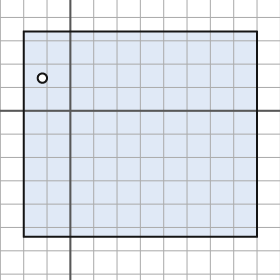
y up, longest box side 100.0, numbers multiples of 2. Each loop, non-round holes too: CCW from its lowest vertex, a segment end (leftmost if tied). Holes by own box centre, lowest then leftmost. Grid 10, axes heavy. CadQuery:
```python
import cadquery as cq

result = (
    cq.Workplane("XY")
    .moveTo(-20.0, -54.0)
    .lineTo(80.0, -54.0)
    .lineTo(80.0, 34.0)
    .lineTo(-20.0, 34.0)
    .close()
    .moveTo(-12.0, 14.0)
    .circle(2.0)
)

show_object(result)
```